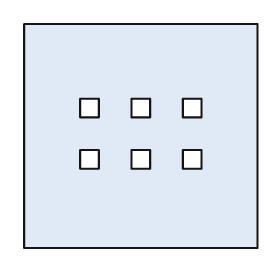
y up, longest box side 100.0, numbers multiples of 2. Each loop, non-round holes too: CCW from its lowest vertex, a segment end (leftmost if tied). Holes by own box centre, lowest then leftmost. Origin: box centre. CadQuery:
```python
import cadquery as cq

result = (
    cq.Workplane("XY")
    .moveTo(-50.0, -48.0)
    .lineTo(50.0, -48.0)
    .lineTo(50.0, 48.0)
    .lineTo(-50.0, 48.0)
    .close()
    .moveTo(-26.0, -14.0)
    .lineTo(-18.0, -14.0)
    .lineTo(-18.0, -6.0)
    .lineTo(-26.0, -6.0)
    .close()
    .moveTo(-4.0, -14.0)
    .lineTo(4.0, -14.0)
    .lineTo(4.0, -6.0)
    .lineTo(-4.0, -6.0)
    .close()
    .moveTo(18.0, -14.0)
    .lineTo(26.0, -14.0)
    .lineTo(26.0, -6.0)
    .lineTo(18.0, -6.0)
    .close()
    .moveTo(-26.0, 8.0)
    .lineTo(-18.0, 8.0)
    .lineTo(-18.0, 16.0)
    .lineTo(-26.0, 16.0)
    .close()
    .moveTo(-4.0, 8.0)
    .lineTo(4.0, 8.0)
    .lineTo(4.0, 16.0)
    .lineTo(-4.0, 16.0)
    .close()
    .moveTo(18.0, 8.0)
    .lineTo(26.0, 8.0)
    .lineTo(26.0, 16.0)
    .lineTo(18.0, 16.0)
    .close()
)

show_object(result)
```